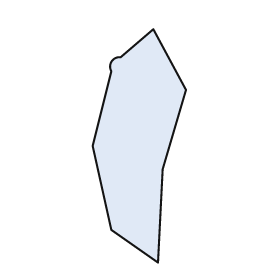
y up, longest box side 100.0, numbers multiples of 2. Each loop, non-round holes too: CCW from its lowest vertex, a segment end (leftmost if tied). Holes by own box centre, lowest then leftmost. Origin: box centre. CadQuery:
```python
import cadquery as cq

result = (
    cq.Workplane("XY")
    .moveTo(8.0, -50.0)
    .lineTo(10.0, -10.0)
    .lineTo(20.0, 24.0)
    .lineTo(6.0, 50.0)
    .lineTo(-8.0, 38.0)
    .threePointArc((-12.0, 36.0), (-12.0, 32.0))
    .lineTo(-20.0, 0.0)
    .lineTo(-12.0, -36.0)
    .close()
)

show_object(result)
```